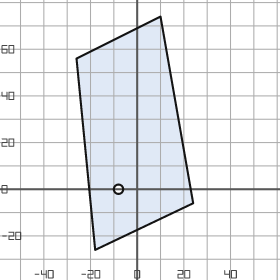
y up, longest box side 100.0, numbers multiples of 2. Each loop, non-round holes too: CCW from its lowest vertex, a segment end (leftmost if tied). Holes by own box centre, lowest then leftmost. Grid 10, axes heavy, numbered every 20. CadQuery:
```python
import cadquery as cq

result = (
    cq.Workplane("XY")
    .moveTo(-18.0, -26.0)
    .lineTo(24.0, -6.0)
    .lineTo(10.0, 74.0)
    .lineTo(-26.0, 56.0)
    .close()
    .moveTo(-8.0, 0.0)
    .circle(2.0)
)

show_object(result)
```